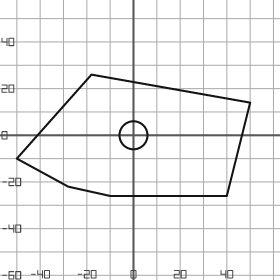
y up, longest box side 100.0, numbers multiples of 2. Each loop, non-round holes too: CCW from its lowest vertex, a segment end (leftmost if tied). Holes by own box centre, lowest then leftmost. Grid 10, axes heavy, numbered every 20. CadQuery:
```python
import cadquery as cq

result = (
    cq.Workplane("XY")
    .moveTo(-10.0, -26.0)
    .lineTo(40.0, -26.0)
    .lineTo(50.0, 14.0)
    .lineTo(-18.0, 26.0)
    .lineTo(-50.0, -10.0)
    .lineTo(-28.0, -22.0)
    .close()
    .moveTo(0.0, 0.0)
    .circle(6.0)
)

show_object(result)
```